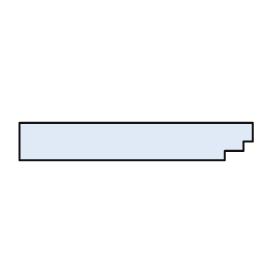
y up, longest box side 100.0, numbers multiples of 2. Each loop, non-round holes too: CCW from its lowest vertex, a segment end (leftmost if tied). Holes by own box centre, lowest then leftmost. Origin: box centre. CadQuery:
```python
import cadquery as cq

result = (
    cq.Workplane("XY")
    .moveTo(-50.0, -8.0)
    .lineTo(38.0, -8.0)
    .lineTo(38.0, -4.0)
    .lineTo(46.0, -4.0)
    .lineTo(46.0, 0.0)
    .lineTo(50.0, 0.0)
    .lineTo(50.0, 8.0)
    .lineTo(-50.0, 8.0)
    .close()
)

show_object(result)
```